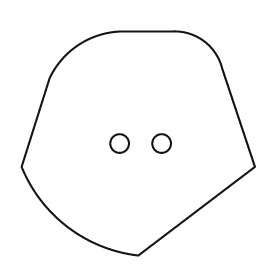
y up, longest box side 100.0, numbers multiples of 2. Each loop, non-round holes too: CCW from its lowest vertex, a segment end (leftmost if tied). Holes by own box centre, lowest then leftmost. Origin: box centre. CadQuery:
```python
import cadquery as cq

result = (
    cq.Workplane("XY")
    .moveTo(0.0, -48.0)
    .lineTo(50.0, -10.0)
    .lineTo(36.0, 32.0)
    .threePointArc((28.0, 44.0), (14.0, 48.0))
    .lineTo(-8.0, 48.0)
    .threePointArc((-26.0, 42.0), (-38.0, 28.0))
    .lineTo(-50.0, -10.0)
    .threePointArc((-30.0, -36.0), (0.0, -48.0))
    .close()
    .moveTo(-8.0, 0.0)
    .circle(4.0)
    .moveTo(10.0, 0.0)
    .circle(4.0)
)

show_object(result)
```